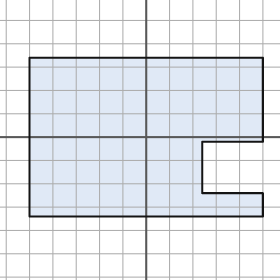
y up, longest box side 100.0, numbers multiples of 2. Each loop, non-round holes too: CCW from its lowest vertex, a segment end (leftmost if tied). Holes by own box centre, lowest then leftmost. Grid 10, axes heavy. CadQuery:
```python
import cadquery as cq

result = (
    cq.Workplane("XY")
    .moveTo(-50.0, -34.0)
    .lineTo(50.0, -34.0)
    .lineTo(50.0, -24.0)
    .lineTo(24.0, -24.0)
    .lineTo(24.0, -2.0)
    .lineTo(50.0, -2.0)
    .lineTo(50.0, 34.0)
    .lineTo(-50.0, 34.0)
    .close()
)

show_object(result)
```